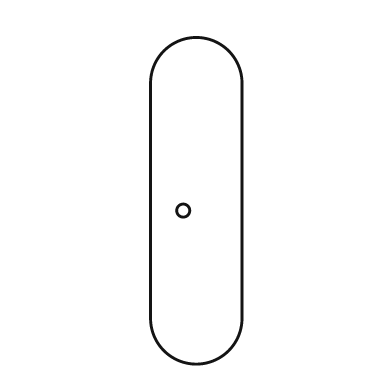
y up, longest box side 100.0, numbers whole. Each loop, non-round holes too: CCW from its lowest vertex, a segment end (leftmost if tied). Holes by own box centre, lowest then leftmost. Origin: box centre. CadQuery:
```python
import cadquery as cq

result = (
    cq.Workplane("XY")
    .moveTo(-14.0, -36.0)
    .threePointArc((0.0, -50.0), (14.0, -36.0))
    .lineTo(14.0, 36.0)
    .threePointArc((0.0, 50.0), (-14.0, 36.0))
    .close()
    .moveTo(-4.0, -3.0)
    .circle(2.0)
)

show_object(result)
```